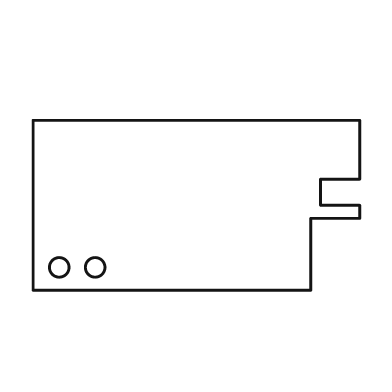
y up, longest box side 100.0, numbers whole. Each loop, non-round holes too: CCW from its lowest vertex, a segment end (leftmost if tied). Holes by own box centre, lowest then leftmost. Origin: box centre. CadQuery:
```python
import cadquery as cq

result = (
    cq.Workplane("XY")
    .moveTo(-50.0, -26.0)
    .lineTo(35.0, -26.0)
    .lineTo(35.0, -4.0)
    .lineTo(50.0, -4.0)
    .lineTo(50.0, 0.0)
    .lineTo(38.0, 0.0)
    .lineTo(38.0, 8.0)
    .lineTo(50.0, 8.0)
    .lineTo(50.0, 26.0)
    .lineTo(-50.0, 26.0)
    .close()
    .moveTo(-42.0, -19.0)
    .circle(3.0)
    .moveTo(-31.0, -19.0)
    .circle(3.0)
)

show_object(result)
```